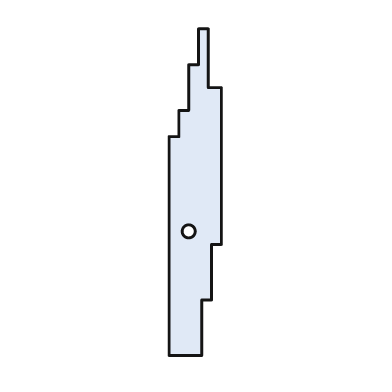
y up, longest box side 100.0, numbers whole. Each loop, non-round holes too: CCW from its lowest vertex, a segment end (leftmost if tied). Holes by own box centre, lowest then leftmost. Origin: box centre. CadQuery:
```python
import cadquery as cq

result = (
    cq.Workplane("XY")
    .moveTo(-8.0, -50.0)
    .lineTo(2.0, -50.0)
    .lineTo(2.0, -33.0)
    .lineTo(5.0, -33.0)
    .lineTo(5.0, -16.0)
    .lineTo(8.0, -16.0)
    .lineTo(8.0, 32.0)
    .lineTo(4.0, 32.0)
    .lineTo(4.0, 50.0)
    .lineTo(1.0, 50.0)
    .lineTo(1.0, 39.0)
    .lineTo(-2.0, 39.0)
    .lineTo(-2.0, 25.0)
    .lineTo(-5.0, 25.0)
    .lineTo(-5.0, 17.0)
    .lineTo(-8.0, 17.0)
    .close()
    .moveTo(-2.0, -12.0)
    .circle(2.0)
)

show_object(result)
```